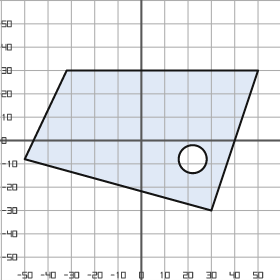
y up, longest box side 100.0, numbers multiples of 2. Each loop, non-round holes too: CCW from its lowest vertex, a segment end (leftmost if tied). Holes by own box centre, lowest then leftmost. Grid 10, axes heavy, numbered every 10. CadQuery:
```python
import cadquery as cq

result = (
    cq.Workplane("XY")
    .moveTo(30.0, -30.0)
    .lineTo(50.0, 30.0)
    .lineTo(-32.0, 30.0)
    .lineTo(-50.0, -8.0)
    .close()
    .moveTo(22.0, -8.0)
    .circle(6.0)
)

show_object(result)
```